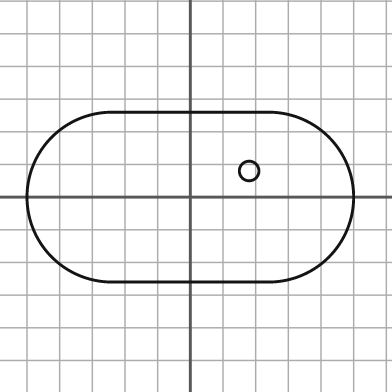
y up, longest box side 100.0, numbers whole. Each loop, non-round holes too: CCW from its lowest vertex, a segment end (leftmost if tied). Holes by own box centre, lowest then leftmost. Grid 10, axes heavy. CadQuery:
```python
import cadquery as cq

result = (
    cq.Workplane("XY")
    .moveTo(-24.0, -26.0)
    .lineTo(24.0, -26.0)
    .threePointArc((50.0, 0.0), (24.0, 26.0))
    .lineTo(-24.0, 26.0)
    .threePointArc((-50.0, 0.0), (-24.0, -26.0))
    .close()
    .moveTo(18.0, 8.0)
    .circle(3.0)
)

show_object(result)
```